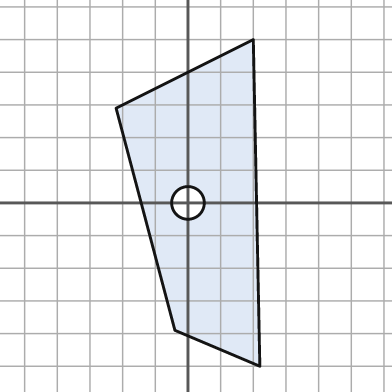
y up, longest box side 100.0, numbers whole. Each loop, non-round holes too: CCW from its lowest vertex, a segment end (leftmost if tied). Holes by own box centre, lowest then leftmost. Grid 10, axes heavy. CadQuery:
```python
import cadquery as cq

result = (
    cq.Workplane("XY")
    .moveTo(22.0, -50.0)
    .lineTo(20.0, 50.0)
    .lineTo(-22.0, 29.0)
    .lineTo(-4.0, -39.0)
    .close()
    .moveTo(0.0, 0.0)
    .circle(5.0)
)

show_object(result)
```